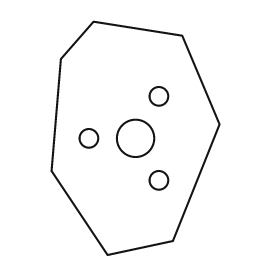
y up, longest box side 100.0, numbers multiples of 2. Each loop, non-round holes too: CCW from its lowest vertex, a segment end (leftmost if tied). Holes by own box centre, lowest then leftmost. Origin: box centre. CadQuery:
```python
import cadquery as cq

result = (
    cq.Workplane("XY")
    .moveTo(-12.0, -50.0)
    .lineTo(16.0, -44.0)
    .lineTo(36.0, 6.0)
    .lineTo(20.0, 44.0)
    .lineTo(-18.0, 50.0)
    .lineTo(-32.0, 34.0)
    .lineTo(-36.0, -14.0)
    .close()
    .moveTo(10.0, -18.0)
    .circle(4.0)
    .moveTo(-20.0, 0.0)
    .circle(4.0)
    .moveTo(0.0, 0.0)
    .circle(8.0)
    .moveTo(10.0, 18.0)
    .circle(4.0)
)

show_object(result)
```